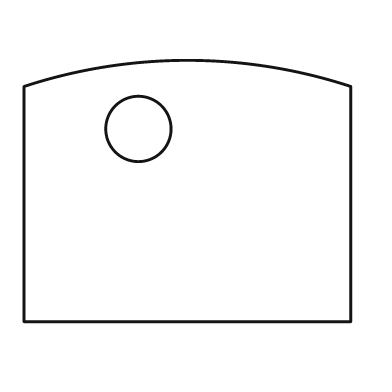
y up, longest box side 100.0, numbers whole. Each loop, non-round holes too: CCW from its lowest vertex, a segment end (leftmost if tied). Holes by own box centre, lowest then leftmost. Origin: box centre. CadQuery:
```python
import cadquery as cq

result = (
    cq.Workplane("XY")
    .moveTo(-50.0, -40.0)
    .lineTo(50.0, -40.0)
    .lineTo(50.0, 32.0)
    .threePointArc((0.0, 40.0), (-50.0, 32.0))
    .close()
    .moveTo(-15.0, 19.0)
    .circle(10.0)
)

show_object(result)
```